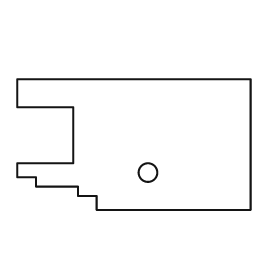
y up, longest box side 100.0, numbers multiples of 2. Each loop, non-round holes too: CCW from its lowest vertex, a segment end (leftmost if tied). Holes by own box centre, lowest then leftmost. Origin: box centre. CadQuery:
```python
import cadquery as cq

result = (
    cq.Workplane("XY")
    .moveTo(-16.0, -28.0)
    .lineTo(50.0, -28.0)
    .lineTo(50.0, 28.0)
    .lineTo(-50.0, 28.0)
    .lineTo(-50.0, 16.0)
    .lineTo(-26.0, 16.0)
    .lineTo(-26.0, -8.0)
    .lineTo(-50.0, -8.0)
    .lineTo(-50.0, -14.0)
    .lineTo(-42.0, -14.0)
    .lineTo(-42.0, -18.0)
    .lineTo(-24.0, -18.0)
    .lineTo(-24.0, -22.0)
    .lineTo(-16.0, -22.0)
    .close()
    .moveTo(6.0, -12.0)
    .circle(4.0)
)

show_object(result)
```